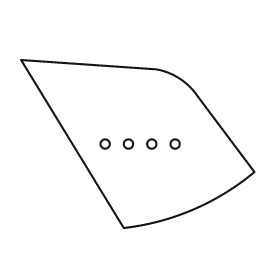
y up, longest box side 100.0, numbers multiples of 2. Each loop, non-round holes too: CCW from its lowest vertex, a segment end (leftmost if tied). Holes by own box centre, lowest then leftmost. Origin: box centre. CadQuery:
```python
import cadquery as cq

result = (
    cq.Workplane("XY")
    .moveTo(-6.0, -36.0)
    .threePointArc((24.0, -28.0), (50.0, -12.0))
    .lineTo(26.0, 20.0)
    .threePointArc((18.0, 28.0), (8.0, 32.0))
    .lineTo(-50.0, 36.0)
    .close()
    .moveTo(-14.0, 0.0)
    .circle(2.0)
    .moveTo(-4.0, 0.0)
    .circle(2.0)
    .moveTo(6.0, 0.0)
    .circle(2.0)
    .moveTo(16.0, 0.0)
    .circle(2.0)
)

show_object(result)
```